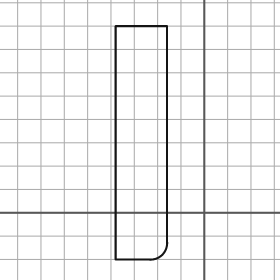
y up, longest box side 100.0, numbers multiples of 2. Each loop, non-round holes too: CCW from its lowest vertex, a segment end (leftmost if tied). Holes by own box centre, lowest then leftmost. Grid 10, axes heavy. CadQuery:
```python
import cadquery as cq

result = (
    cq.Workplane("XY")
    .moveTo(-38.0, -20.0)
    .lineTo(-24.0, -20.0)
    .threePointArc((-18.0, -18.0), (-16.0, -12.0))
    .lineTo(-16.0, 80.0)
    .lineTo(-38.0, 80.0)
    .close()
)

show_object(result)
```